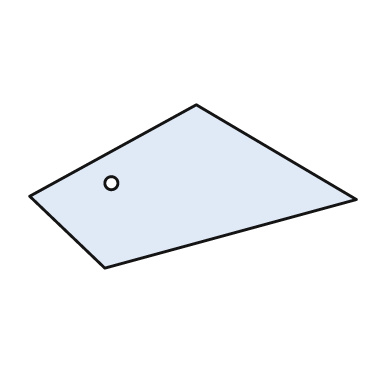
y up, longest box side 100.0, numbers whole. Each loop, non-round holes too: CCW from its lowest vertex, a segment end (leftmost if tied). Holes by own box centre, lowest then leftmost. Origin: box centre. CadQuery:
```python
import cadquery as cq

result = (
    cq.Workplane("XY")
    .moveTo(-27.0, -25.0)
    .lineTo(50.0, -4.0)
    .lineTo(1.0, 25.0)
    .lineTo(-50.0, -3.0)
    .close()
    .moveTo(-25.0, 1.0)
    .circle(2.0)
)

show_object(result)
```